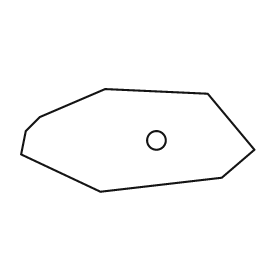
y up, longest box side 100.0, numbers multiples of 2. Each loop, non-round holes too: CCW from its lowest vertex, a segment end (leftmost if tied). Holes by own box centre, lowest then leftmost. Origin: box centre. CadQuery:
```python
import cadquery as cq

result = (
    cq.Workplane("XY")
    .moveTo(-16.0, -22.0)
    .lineTo(36.0, -16.0)
    .lineTo(50.0, -4.0)
    .lineTo(30.0, 20.0)
    .lineTo(-14.0, 22.0)
    .lineTo(-42.0, 10.0)
    .lineTo(-48.0, 4.0)
    .lineTo(-50.0, -6.0)
    .close()
    .moveTo(8.0, 0.0)
    .circle(4.0)
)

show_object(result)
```